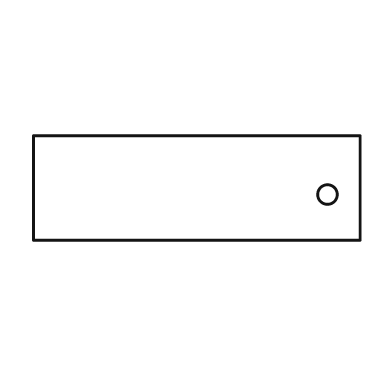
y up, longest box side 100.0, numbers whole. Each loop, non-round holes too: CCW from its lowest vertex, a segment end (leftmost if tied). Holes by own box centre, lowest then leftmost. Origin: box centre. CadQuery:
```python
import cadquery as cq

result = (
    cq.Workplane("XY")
    .moveTo(-50.0, -16.0)
    .lineTo(50.0, -16.0)
    .lineTo(50.0, 16.0)
    .lineTo(-50.0, 16.0)
    .close()
    .moveTo(40.0, -2.0)
    .circle(3.0)
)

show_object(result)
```